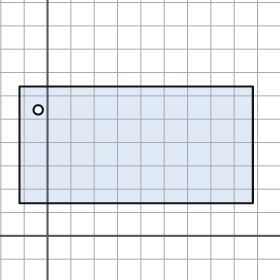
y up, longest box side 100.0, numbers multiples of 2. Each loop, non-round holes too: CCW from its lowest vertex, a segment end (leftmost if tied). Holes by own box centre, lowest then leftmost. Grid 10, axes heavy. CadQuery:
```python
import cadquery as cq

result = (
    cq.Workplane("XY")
    .moveTo(-12.0, 14.0)
    .lineTo(88.0, 14.0)
    .lineTo(88.0, 64.0)
    .lineTo(-12.0, 64.0)
    .close()
    .moveTo(-4.0, 54.0)
    .circle(2.0)
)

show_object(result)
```